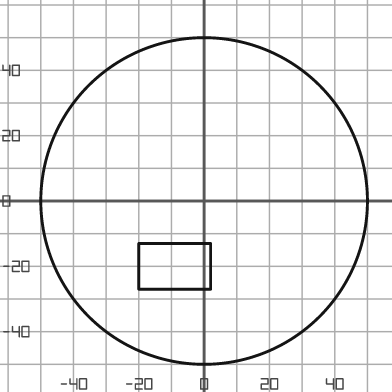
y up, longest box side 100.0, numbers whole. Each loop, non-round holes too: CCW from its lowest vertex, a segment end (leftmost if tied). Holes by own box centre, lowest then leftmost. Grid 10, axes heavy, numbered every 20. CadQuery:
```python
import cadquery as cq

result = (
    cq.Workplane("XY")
    .moveTo(0.0, 0.0)
    .circle(50.0)
    .moveTo(-20.0, -27.0)
    .lineTo(2.0, -27.0)
    .lineTo(2.0, -13.0)
    .lineTo(-20.0, -13.0)
    .close()
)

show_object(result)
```